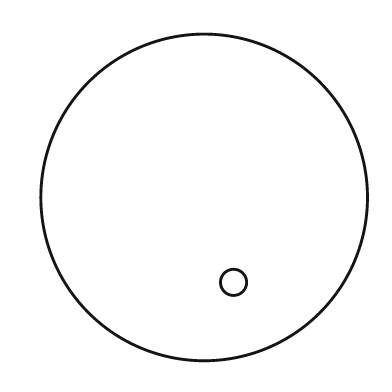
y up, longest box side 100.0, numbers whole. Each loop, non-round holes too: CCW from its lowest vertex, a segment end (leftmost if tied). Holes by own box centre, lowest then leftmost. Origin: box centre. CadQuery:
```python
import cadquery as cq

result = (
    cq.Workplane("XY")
    .moveTo(0.0, 0.0)
    .circle(50.0)
    .moveTo(9.0, -26.0)
    .circle(4.0)
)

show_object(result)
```